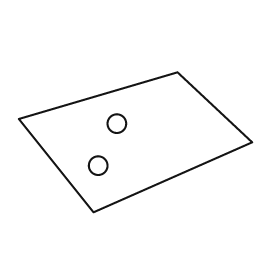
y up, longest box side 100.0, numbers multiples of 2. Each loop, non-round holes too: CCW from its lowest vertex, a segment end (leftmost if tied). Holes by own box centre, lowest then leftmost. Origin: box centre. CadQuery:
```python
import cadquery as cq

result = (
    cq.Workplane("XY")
    .moveTo(-18.0, -30.0)
    .lineTo(50.0, 0.0)
    .lineTo(18.0, 30.0)
    .lineTo(-50.0, 10.0)
    .close()
    .moveTo(-16.0, -10.0)
    .circle(4.0)
    .moveTo(-8.0, 8.0)
    .circle(4.0)
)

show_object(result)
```